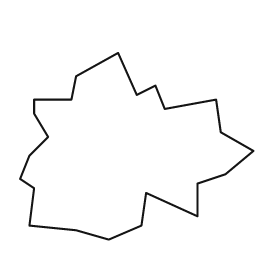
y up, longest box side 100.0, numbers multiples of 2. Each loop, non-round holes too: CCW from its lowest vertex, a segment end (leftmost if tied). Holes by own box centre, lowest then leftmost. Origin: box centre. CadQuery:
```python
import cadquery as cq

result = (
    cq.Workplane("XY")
    .moveTo(-12.0, -40.0)
    .lineTo(2.0, -34.0)
    .lineTo(4.0, -20.0)
    .lineTo(26.0, -30.0)
    .lineTo(26.0, -16.0)
    .lineTo(38.0, -12.0)
    .lineTo(50.0, -2.0)
    .lineTo(36.0, 6.0)
    .lineTo(34.0, 20.0)
    .lineTo(12.0, 16.0)
    .lineTo(8.0, 26.0)
    .lineTo(0.0, 22.0)
    .lineTo(-8.0, 40.0)
    .lineTo(-26.0, 30.0)
    .lineTo(-28.0, 20.0)
    .lineTo(-44.0, 20.0)
    .lineTo(-44.0, 14.0)
    .lineTo(-38.0, 4.0)
    .lineTo(-46.0, -4.0)
    .lineTo(-50.0, -14.0)
    .lineTo(-44.0, -18.0)
    .lineTo(-46.0, -34.0)
    .lineTo(-26.0, -36.0)
    .close()
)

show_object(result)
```